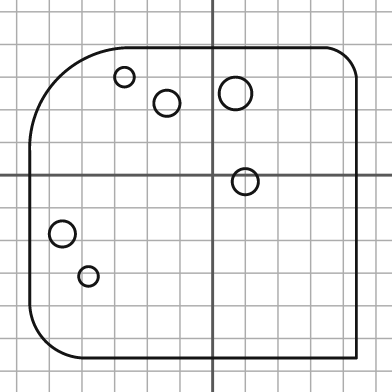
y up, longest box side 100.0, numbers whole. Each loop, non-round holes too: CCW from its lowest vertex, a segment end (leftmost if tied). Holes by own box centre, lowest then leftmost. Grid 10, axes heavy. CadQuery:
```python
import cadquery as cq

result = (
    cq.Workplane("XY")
    .moveTo(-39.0, -56.0)
    .lineTo(44.0, -56.0)
    .lineTo(44.0, 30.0)
    .threePointArc((41.0, 36.0), (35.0, 39.0))
    .lineTo(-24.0, 39.0)
    .threePointArc((-47.0, 30.0), (-56.0, 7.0))
    .lineTo(-56.0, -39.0)
    .threePointArc((-51.0, -51.0), (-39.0, -56.0))
    .close()
    .moveTo(-38.0, -31.0)
    .circle(3.0)
    .moveTo(-46.0, -18.0)
    .circle(4.0)
    .moveTo(10.0, -2.0)
    .circle(4.0)
    .moveTo(-14.0, 22.0)
    .circle(4.0)
    .moveTo(7.0, 25.0)
    .circle(5.0)
    .moveTo(-27.0, 30.0)
    .circle(3.0)
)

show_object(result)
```